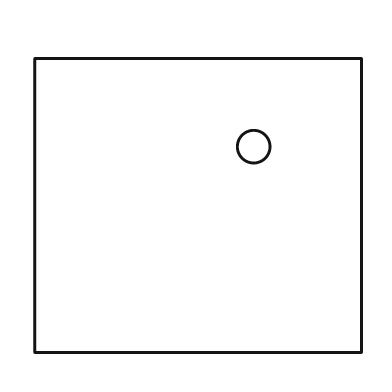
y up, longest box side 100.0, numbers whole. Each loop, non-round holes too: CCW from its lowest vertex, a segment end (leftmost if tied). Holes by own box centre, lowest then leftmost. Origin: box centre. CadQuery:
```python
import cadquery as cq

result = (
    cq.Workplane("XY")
    .moveTo(-50.0, -45.0)
    .lineTo(50.0, -45.0)
    .lineTo(50.0, 45.0)
    .lineTo(-50.0, 45.0)
    .close()
    .moveTo(17.0, 18.0)
    .circle(5.0)
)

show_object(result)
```